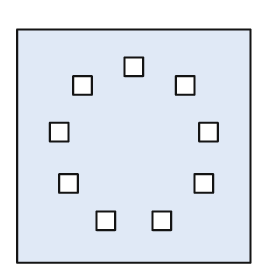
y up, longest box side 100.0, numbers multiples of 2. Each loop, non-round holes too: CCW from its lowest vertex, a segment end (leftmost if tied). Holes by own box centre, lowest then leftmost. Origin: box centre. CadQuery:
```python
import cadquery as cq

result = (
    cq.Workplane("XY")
    .moveTo(-50.0, -50.0)
    .lineTo(50.0, -50.0)
    .lineTo(50.0, 50.0)
    .lineTo(-50.0, 50.0)
    .close()
    .moveTo(-16.0, -36.0)
    .lineTo(-8.0, -36.0)
    .lineTo(-8.0, -28.0)
    .lineTo(-16.0, -28.0)
    .close()
    .moveTo(8.0, -36.0)
    .lineTo(16.0, -36.0)
    .lineTo(16.0, -28.0)
    .lineTo(8.0, -28.0)
    .close()
    .moveTo(-32.0, -20.0)
    .lineTo(-24.0, -20.0)
    .lineTo(-24.0, -12.0)
    .lineTo(-32.0, -12.0)
    .close()
    .moveTo(26.0, -20.0)
    .lineTo(34.0, -20.0)
    .lineTo(34.0, -12.0)
    .lineTo(26.0, -12.0)
    .close()
    .moveTo(-36.0, 2.0)
    .lineTo(-28.0, 2.0)
    .lineTo(-28.0, 10.0)
    .lineTo(-36.0, 10.0)
    .close()
    .moveTo(28.0, 2.0)
    .lineTo(36.0, 2.0)
    .lineTo(36.0, 10.0)
    .lineTo(28.0, 10.0)
    .close()
    .moveTo(-26.0, 22.0)
    .lineTo(-18.0, 22.0)
    .lineTo(-18.0, 30.0)
    .lineTo(-26.0, 30.0)
    .close()
    .moveTo(18.0, 22.0)
    .lineTo(26.0, 22.0)
    .lineTo(26.0, 30.0)
    .lineTo(18.0, 30.0)
    .close()
    .moveTo(-4.0, 30.0)
    .lineTo(4.0, 30.0)
    .lineTo(4.0, 38.0)
    .lineTo(-4.0, 38.0)
    .close()
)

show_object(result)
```